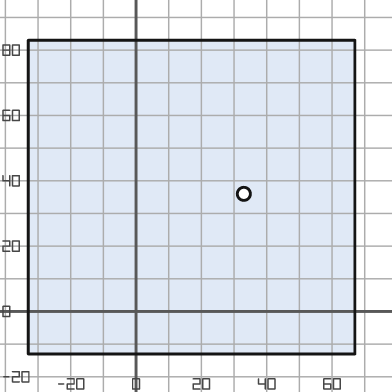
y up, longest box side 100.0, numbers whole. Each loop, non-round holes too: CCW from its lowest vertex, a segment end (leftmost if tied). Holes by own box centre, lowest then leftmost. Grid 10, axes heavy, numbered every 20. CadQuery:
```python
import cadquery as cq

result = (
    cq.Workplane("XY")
    .moveTo(-33.0, -13.0)
    .lineTo(67.0, -13.0)
    .lineTo(67.0, 83.0)
    .lineTo(-33.0, 83.0)
    .close()
    .moveTo(33.0, 36.0)
    .circle(2.0)
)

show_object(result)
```